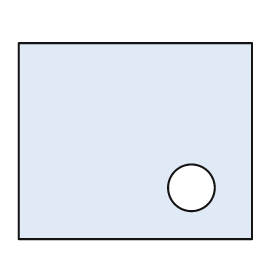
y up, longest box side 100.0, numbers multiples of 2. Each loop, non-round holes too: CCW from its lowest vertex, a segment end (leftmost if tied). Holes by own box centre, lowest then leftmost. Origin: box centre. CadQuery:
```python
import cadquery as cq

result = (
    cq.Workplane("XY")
    .moveTo(-50.0, -42.0)
    .lineTo(50.0, -42.0)
    .lineTo(50.0, 42.0)
    .lineTo(-50.0, 42.0)
    .close()
    .moveTo(24.0, -20.0)
    .circle(10.0)
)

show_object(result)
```